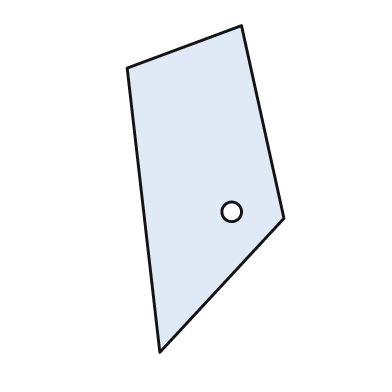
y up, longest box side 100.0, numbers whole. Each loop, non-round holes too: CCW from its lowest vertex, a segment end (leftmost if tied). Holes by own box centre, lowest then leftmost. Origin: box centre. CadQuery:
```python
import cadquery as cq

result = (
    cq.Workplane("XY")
    .moveTo(-14.0, -50.0)
    .lineTo(24.0, -9.0)
    .lineTo(11.0, 50.0)
    .lineTo(-24.0, 37.0)
    .close()
    .moveTo(8.0, -7.0)
    .circle(3.0)
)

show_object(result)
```